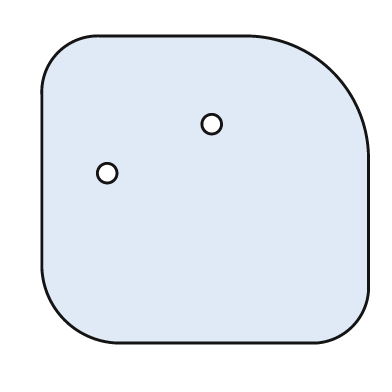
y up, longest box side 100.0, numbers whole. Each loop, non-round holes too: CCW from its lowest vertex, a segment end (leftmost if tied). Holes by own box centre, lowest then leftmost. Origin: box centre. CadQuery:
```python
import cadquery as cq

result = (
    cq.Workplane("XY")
    .moveTo(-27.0, -47.0)
    .lineTo(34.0, -47.0)
    .threePointArc((45.0, -42.0), (50.0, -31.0))
    .lineTo(50.0, 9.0)
    .threePointArc((39.0, 36.0), (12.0, 47.0))
    .lineTo(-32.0, 47.0)
    .threePointArc((-45.0, 42.0), (-50.0, 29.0))
    .lineTo(-50.0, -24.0)
    .threePointArc((-43.0, -40.0), (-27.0, -47.0))
    .close()
    .moveTo(-30.0, 5.0)
    .circle(3.0)
    .moveTo(2.0, 20.0)
    .circle(3.0)
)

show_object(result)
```